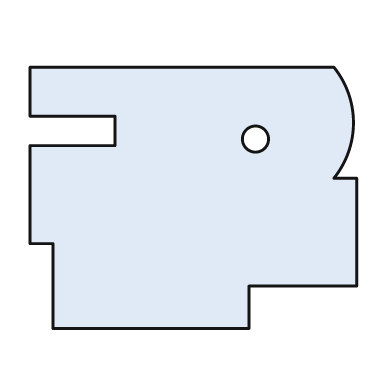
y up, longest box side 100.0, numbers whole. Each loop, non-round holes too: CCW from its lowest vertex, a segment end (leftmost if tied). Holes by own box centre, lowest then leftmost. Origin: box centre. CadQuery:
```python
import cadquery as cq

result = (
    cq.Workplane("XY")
    .moveTo(-43.0, -40.0)
    .lineTo(17.0, -40.0)
    .lineTo(17.0, -27.0)
    .lineTo(50.0, -27.0)
    .lineTo(50.0, 6.0)
    .lineTo(43.0, 6.0)
    .threePointArc((49.0, 23.0), (43.0, 40.0))
    .lineTo(-50.0, 40.0)
    .lineTo(-50.0, 25.0)
    .lineTo(-24.0, 25.0)
    .lineTo(-24.0, 16.0)
    .lineTo(-50.0, 16.0)
    .lineTo(-50.0, -14.0)
    .lineTo(-43.0, -14.0)
    .close()
    .moveTo(19.0, 18.0)
    .circle(4.0)
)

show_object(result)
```